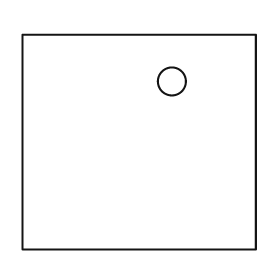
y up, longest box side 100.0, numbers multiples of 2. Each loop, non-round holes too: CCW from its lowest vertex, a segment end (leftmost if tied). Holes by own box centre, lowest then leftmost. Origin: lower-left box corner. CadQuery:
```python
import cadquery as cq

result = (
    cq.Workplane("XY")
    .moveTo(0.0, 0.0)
    .lineTo(100.0, 0.0)
    .lineTo(100.0, 92.0)
    .lineTo(0.0, 92.0)
    .close()
    .moveTo(64.0, 72.0)
    .circle(6.0)
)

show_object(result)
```